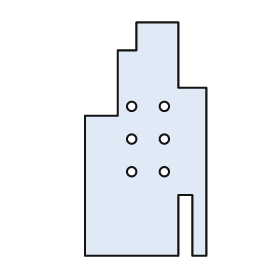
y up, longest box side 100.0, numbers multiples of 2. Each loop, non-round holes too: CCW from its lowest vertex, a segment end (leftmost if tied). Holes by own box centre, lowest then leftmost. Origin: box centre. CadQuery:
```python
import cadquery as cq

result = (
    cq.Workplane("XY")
    .moveTo(-26.0, -50.0)
    .lineTo(14.0, -50.0)
    .lineTo(14.0, -24.0)
    .lineTo(20.0, -24.0)
    .lineTo(20.0, -50.0)
    .lineTo(26.0, -50.0)
    .lineTo(26.0, 22.0)
    .lineTo(14.0, 22.0)
    .lineTo(14.0, 50.0)
    .lineTo(-4.0, 50.0)
    .lineTo(-4.0, 38.0)
    .lineTo(-12.0, 38.0)
    .lineTo(-12.0, 10.0)
    .lineTo(-26.0, 10.0)
    .close()
    .moveTo(-6.0, -14.0)
    .circle(2.0)
    .moveTo(8.0, -14.0)
    .circle(2.0)
    .moveTo(-6.0, 0.0)
    .circle(2.0)
    .moveTo(8.0, 0.0)
    .circle(2.0)
    .moveTo(-6.0, 14.0)
    .circle(2.0)
    .moveTo(8.0, 14.0)
    .circle(2.0)
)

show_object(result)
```